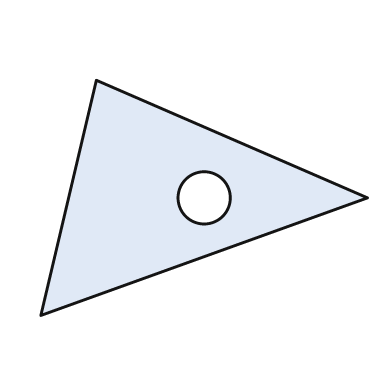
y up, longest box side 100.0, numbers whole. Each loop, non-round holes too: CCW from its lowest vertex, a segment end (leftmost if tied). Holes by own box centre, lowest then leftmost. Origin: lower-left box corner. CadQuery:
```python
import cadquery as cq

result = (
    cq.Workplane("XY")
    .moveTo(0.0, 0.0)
    .lineTo(100.0, 36.0)
    .lineTo(17.0, 72.0)
    .close()
    .moveTo(50.0, 36.0)
    .circle(8.0)
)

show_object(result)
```